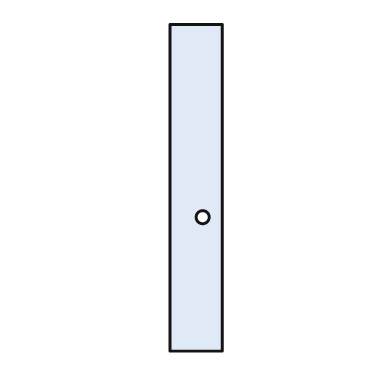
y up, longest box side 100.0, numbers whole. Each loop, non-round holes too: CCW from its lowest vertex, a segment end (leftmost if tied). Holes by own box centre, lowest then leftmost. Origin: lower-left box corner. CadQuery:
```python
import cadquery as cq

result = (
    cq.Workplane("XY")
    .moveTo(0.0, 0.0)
    .lineTo(16.0, 0.0)
    .lineTo(16.0, 100.0)
    .lineTo(0.0, 100.0)
    .close()
    .moveTo(10.0, 41.0)
    .circle(2.0)
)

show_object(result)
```